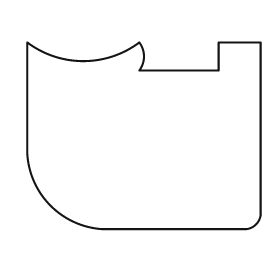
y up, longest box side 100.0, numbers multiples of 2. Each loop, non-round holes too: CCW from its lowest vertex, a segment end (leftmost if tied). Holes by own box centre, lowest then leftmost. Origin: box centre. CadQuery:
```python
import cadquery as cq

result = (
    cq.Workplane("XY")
    .moveTo(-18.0, -40.0)
    .lineTo(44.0, -40.0)
    .threePointArc((48.0, -38.0), (50.0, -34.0))
    .lineTo(50.0, 40.0)
    .lineTo(32.0, 40.0)
    .lineTo(32.0, 28.0)
    .lineTo(-2.0, 28.0)
    .threePointArc((0.0, 34.0), (-2.0, 40.0))
    .threePointArc((-26.0, 32.0), (-50.0, 40.0))
    .lineTo(-50.0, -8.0)
    .threePointArc((-40.0, -30.0), (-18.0, -40.0))
    .close()
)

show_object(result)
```